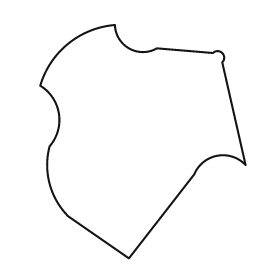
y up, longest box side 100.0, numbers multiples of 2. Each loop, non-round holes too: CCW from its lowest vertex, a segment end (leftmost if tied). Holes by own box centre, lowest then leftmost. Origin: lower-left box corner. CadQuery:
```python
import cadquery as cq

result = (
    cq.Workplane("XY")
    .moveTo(38.0, 0.0)
    .lineTo(66.0, 36.0)
    .threePointArc((76.0, 44.0), (88.0, 40.0))
    .lineTo(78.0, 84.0)
    .threePointArc((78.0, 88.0), (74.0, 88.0))
    .lineTo(50.0, 90.0)
    .threePointArc((38.0, 90.0), (32.0, 100.0))
    .threePointArc((12.0, 92.0), (0.0, 74.0))
    .threePointArc((8.0, 62.0), (4.0, 48.0))
    .threePointArc((4.0, 32.0), (12.0, 18.0))
    .close()
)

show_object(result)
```